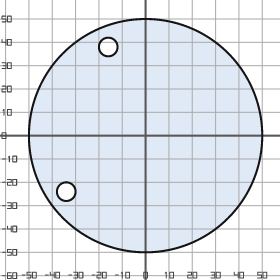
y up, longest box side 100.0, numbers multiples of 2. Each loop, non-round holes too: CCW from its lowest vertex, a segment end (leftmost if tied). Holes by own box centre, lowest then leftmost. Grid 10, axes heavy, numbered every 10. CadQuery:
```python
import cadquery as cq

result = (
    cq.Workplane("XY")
    .moveTo(0.0, 0.0)
    .circle(50.0)
    .moveTo(-34.0, -24.0)
    .circle(4.0)
    .moveTo(-16.0, 38.0)
    .circle(4.0)
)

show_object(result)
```